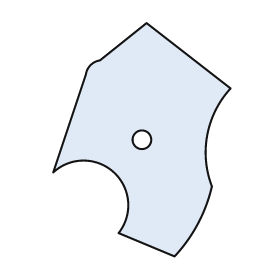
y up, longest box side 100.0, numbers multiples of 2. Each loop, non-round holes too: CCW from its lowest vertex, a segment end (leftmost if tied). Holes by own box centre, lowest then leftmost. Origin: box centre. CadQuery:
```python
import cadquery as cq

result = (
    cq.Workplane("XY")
    .moveTo(14.0, -50.0)
    .threePointArc((24.0, -36.0), (30.0, -20.0))
    .threePointArc((28.0, 2.0), (38.0, 22.0))
    .lineTo(2.0, 50.0)
    .lineTo(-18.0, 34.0)
    .threePointArc((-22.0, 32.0), (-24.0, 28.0))
    .lineTo(-38.0, -14.0)
    .threePointArc((-12.0, -14.0), (-10.0, -40.0))
    .close()
    .moveTo(0.0, 0.0)
    .circle(4.0)
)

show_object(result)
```